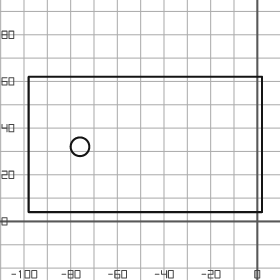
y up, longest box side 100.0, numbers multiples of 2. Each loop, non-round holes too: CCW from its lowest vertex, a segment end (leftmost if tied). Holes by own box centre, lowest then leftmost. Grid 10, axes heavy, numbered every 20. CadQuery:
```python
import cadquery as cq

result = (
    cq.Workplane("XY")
    .moveTo(-98.0, 4.0)
    .lineTo(2.0, 4.0)
    .lineTo(2.0, 62.0)
    .lineTo(-98.0, 62.0)
    .close()
    .moveTo(-76.0, 32.0)
    .circle(4.0)
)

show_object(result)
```